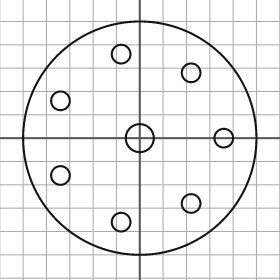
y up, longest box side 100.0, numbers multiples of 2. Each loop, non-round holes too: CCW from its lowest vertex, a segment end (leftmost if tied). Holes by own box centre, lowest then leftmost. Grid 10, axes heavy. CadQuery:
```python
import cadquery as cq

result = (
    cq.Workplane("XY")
    .moveTo(0.0, 0.0)
    .circle(50.0)
    .moveTo(-8.0, -36.0)
    .circle(4.0)
    .moveTo(22.0, -28.0)
    .circle(4.0)
    .moveTo(-34.0, -16.0)
    .circle(4.0)
    .moveTo(0.0, 0.0)
    .circle(6.0)
    .moveTo(36.0, 0.0)
    .circle(4.0)
    .moveTo(-34.0, 16.0)
    .circle(4.0)
    .moveTo(22.0, 28.0)
    .circle(4.0)
    .moveTo(-8.0, 36.0)
    .circle(4.0)
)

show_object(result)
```